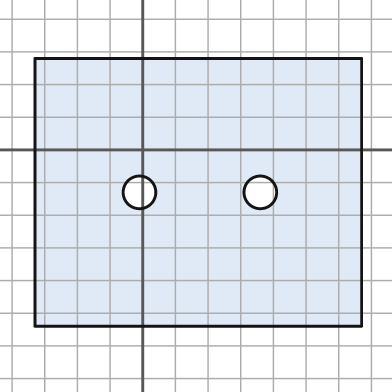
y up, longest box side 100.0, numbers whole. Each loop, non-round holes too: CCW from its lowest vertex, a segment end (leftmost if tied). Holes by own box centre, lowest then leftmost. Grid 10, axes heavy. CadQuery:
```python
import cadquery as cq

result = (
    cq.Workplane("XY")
    .moveTo(-33.0, -54.0)
    .lineTo(67.0, -54.0)
    .lineTo(67.0, 28.0)
    .lineTo(-33.0, 28.0)
    .close()
    .moveTo(-1.0, -13.0)
    .circle(5.0)
    .moveTo(36.0, -13.0)
    .circle(5.0)
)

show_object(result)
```